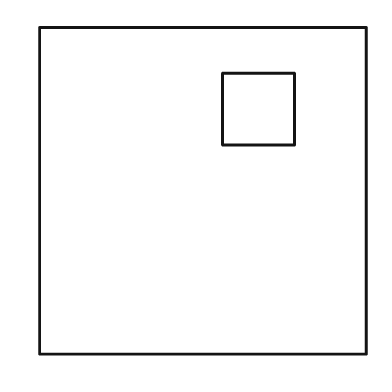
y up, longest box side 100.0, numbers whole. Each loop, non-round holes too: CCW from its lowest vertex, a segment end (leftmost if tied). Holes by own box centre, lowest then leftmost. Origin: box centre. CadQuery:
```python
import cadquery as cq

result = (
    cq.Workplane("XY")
    .moveTo(-50.0, -50.0)
    .lineTo(50.0, -50.0)
    .lineTo(50.0, 50.0)
    .lineTo(-50.0, 50.0)
    .close()
    .moveTo(6.0, 14.0)
    .lineTo(28.0, 14.0)
    .lineTo(28.0, 36.0)
    .lineTo(6.0, 36.0)
    .close()
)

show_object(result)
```